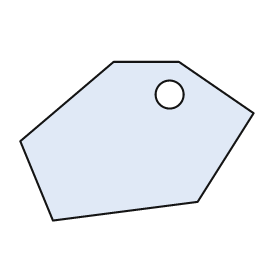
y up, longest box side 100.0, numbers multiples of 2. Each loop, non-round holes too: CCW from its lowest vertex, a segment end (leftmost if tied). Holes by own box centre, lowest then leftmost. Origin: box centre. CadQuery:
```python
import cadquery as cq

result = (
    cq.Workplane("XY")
    .moveTo(-36.0, -34.0)
    .lineTo(26.0, -26.0)
    .lineTo(50.0, 12.0)
    .lineTo(18.0, 34.0)
    .lineTo(-10.0, 34.0)
    .lineTo(-50.0, 0.0)
    .close()
    .moveTo(14.0, 20.0)
    .circle(6.0)
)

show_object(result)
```